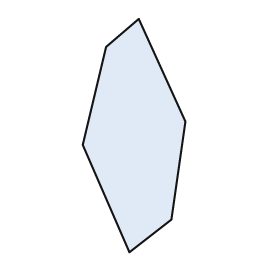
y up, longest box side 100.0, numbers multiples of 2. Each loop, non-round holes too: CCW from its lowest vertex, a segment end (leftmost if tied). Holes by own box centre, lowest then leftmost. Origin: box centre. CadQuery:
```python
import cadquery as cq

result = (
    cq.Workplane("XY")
    .moveTo(-2.0, -50.0)
    .lineTo(16.0, -36.0)
    .lineTo(22.0, 6.0)
    .lineTo(2.0, 50.0)
    .lineTo(-12.0, 38.0)
    .lineTo(-22.0, -4.0)
    .close()
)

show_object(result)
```